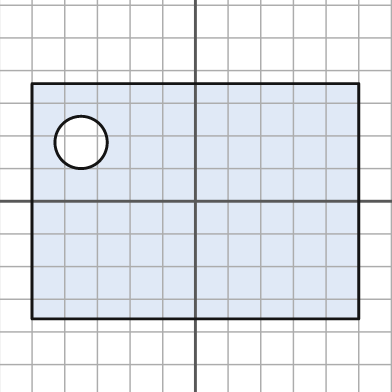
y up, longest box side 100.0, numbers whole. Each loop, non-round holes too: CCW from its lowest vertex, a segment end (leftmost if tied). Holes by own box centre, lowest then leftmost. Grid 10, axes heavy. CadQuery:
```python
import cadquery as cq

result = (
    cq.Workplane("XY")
    .moveTo(-50.0, -36.0)
    .lineTo(50.0, -36.0)
    .lineTo(50.0, 36.0)
    .lineTo(-50.0, 36.0)
    .close()
    .moveTo(-35.0, 18.0)
    .circle(8.0)
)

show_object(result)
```